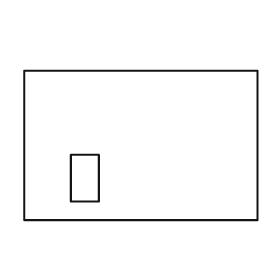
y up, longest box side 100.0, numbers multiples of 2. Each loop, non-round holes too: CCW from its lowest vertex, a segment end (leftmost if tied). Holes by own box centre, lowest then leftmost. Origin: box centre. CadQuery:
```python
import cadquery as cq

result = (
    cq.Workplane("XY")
    .moveTo(-50.0, -32.0)
    .lineTo(50.0, -32.0)
    .lineTo(50.0, 32.0)
    .lineTo(-50.0, 32.0)
    .close()
    .moveTo(-30.0, -24.0)
    .lineTo(-18.0, -24.0)
    .lineTo(-18.0, -4.0)
    .lineTo(-30.0, -4.0)
    .close()
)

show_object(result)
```